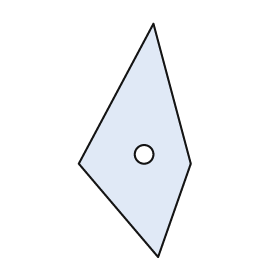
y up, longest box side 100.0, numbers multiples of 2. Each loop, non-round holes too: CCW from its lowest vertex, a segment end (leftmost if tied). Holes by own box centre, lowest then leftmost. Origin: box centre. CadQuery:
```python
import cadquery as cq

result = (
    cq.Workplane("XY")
    .moveTo(10.0, -50.0)
    .lineTo(24.0, -10.0)
    .lineTo(8.0, 50.0)
    .lineTo(-24.0, -10.0)
    .close()
    .moveTo(4.0, -6.0)
    .circle(4.0)
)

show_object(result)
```